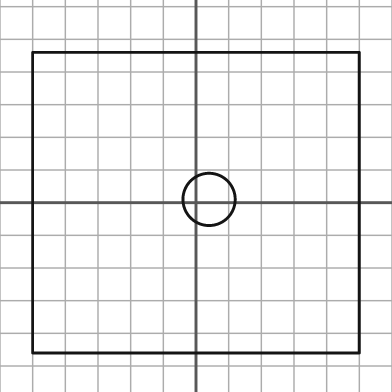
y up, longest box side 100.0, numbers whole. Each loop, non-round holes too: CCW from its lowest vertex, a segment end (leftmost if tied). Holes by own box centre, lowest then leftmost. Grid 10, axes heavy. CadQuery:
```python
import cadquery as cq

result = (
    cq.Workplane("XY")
    .moveTo(-50.0, -46.0)
    .lineTo(50.0, -46.0)
    .lineTo(50.0, 46.0)
    .lineTo(-50.0, 46.0)
    .close()
    .moveTo(4.0, 1.0)
    .circle(8.0)
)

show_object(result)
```